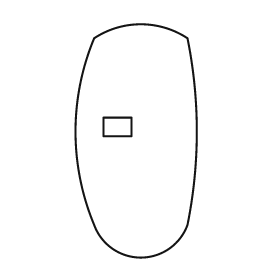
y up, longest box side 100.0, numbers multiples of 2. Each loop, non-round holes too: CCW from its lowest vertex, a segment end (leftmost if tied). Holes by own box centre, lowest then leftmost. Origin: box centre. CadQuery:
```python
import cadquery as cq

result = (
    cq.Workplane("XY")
    .moveTo(-18.0, -36.0)
    .threePointArc((2.0, -50.0), (22.0, -36.0))
    .threePointArc((26.0, 4.0), (22.0, 44.0))
    .threePointArc((2.0, 50.0), (-18.0, 44.0))
    .threePointArc((-26.0, 4.0), (-18.0, -36.0))
    .close()
    .moveTo(-14.0, 2.0)
    .lineTo(-2.0, 2.0)
    .lineTo(-2.0, 10.0)
    .lineTo(-14.0, 10.0)
    .close()
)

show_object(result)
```